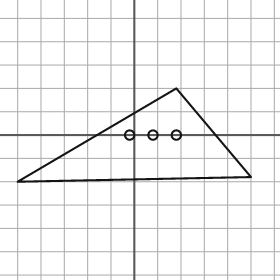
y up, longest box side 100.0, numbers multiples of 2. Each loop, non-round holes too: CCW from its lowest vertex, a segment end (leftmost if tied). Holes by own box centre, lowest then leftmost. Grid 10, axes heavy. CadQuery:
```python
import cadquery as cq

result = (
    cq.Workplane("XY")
    .moveTo(-50.0, -20.0)
    .lineTo(50.0, -18.0)
    .lineTo(18.0, 20.0)
    .close()
    .moveTo(-2.0, 0.0)
    .circle(2.0)
    .moveTo(8.0, 0.0)
    .circle(2.0)
    .moveTo(18.0, 0.0)
    .circle(2.0)
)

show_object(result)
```